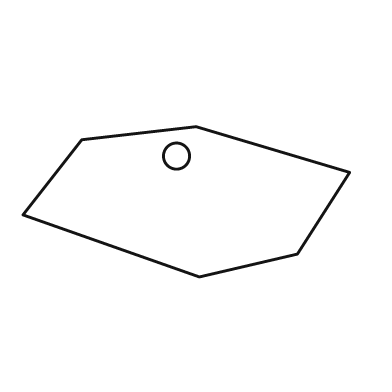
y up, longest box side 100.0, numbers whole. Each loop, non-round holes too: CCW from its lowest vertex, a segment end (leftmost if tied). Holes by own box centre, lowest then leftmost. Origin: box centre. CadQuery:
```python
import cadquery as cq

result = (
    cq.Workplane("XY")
    .moveTo(4.0, -23.0)
    .lineTo(34.0, -16.0)
    .lineTo(50.0, 9.0)
    .lineTo(3.0, 23.0)
    .lineTo(-32.0, 19.0)
    .lineTo(-50.0, -4.0)
    .close()
    .moveTo(-3.0, 14.0)
    .circle(4.0)
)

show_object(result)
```